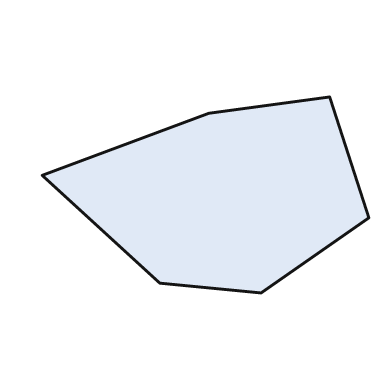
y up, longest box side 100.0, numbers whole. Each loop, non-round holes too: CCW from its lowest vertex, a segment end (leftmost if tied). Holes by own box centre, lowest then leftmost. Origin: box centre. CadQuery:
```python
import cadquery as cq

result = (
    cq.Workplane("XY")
    .moveTo(17.0, -30.0)
    .lineTo(50.0, -7.0)
    .lineTo(38.0, 30.0)
    .lineTo(1.0, 25.0)
    .lineTo(-50.0, 6.0)
    .lineTo(-14.0, -27.0)
    .close()
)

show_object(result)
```